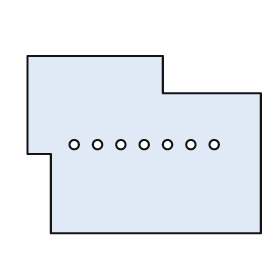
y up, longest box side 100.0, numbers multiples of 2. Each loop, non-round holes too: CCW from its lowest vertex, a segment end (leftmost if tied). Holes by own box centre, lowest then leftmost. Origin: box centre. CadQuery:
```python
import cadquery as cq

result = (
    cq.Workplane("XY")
    .moveTo(-40.0, -38.0)
    .lineTo(50.0, -38.0)
    .lineTo(50.0, 22.0)
    .lineTo(8.0, 22.0)
    .lineTo(8.0, 38.0)
    .lineTo(-50.0, 38.0)
    .lineTo(-50.0, -4.0)
    .lineTo(-40.0, -4.0)
    .close()
    .moveTo(-30.0, 0.0)
    .circle(2.0)
    .moveTo(-20.0, 0.0)
    .circle(2.0)
    .moveTo(-10.0, 0.0)
    .circle(2.0)
    .moveTo(0.0, 0.0)
    .circle(2.0)
    .moveTo(10.0, 0.0)
    .circle(2.0)
    .moveTo(20.0, 0.0)
    .circle(2.0)
    .moveTo(30.0, 0.0)
    .circle(2.0)
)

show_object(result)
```